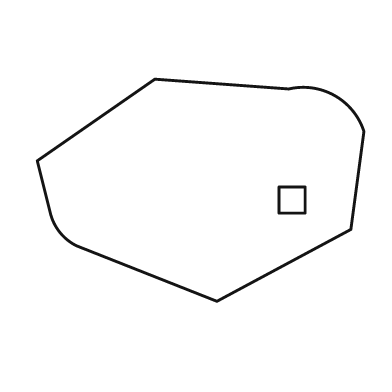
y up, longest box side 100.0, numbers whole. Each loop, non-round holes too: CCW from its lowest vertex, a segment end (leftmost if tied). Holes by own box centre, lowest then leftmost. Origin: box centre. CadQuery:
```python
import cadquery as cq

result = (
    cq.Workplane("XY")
    .moveTo(5.0, -34.0)
    .lineTo(46.0, -12.0)
    .lineTo(50.0, 18.0)
    .threePointArc((41.0, 29.0), (27.0, 31.0))
    .lineTo(-14.0, 34.0)
    .lineTo(-50.0, 9.0)
    .lineTo(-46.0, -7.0)
    .threePointArc((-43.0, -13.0), (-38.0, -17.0))
    .close()
    .moveTo(24.0, -7.0)
    .lineTo(32.0, -7.0)
    .lineTo(32.0, 1.0)
    .lineTo(24.0, 1.0)
    .close()
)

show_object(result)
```